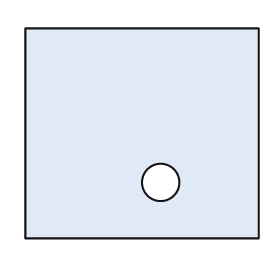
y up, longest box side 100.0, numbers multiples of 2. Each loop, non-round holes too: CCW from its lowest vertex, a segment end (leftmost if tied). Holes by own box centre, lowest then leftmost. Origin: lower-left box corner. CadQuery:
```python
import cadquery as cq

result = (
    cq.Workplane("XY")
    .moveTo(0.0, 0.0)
    .lineTo(100.0, 0.0)
    .lineTo(100.0, 90.0)
    .lineTo(0.0, 90.0)
    .close()
    .moveTo(58.0, 24.0)
    .circle(8.0)
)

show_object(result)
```